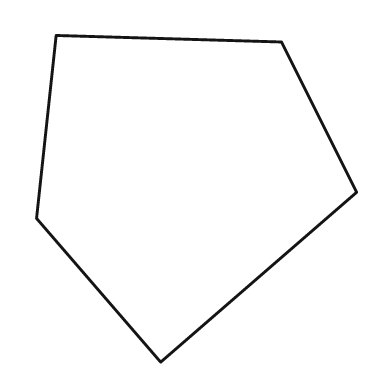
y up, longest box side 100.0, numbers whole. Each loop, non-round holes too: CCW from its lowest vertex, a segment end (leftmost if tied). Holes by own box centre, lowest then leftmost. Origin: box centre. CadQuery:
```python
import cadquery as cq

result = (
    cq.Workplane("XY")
    .moveTo(-11.0, -50.0)
    .lineTo(49.0, 2.0)
    .lineTo(26.0, 48.0)
    .lineTo(-43.0, 50.0)
    .lineTo(-49.0, -6.0)
    .close()
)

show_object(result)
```